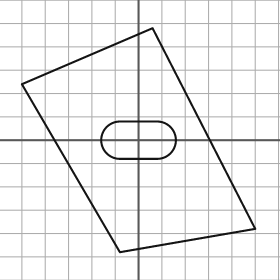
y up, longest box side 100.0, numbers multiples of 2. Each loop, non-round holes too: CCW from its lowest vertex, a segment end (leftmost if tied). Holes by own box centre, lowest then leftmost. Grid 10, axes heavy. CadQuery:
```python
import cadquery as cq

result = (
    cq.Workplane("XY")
    .moveTo(-8.0, -48.0)
    .lineTo(50.0, -38.0)
    .lineTo(6.0, 48.0)
    .lineTo(-50.0, 24.0)
    .close()
    .moveTo(-8.0, -8.0)
    .lineTo(8.0, -8.0)
    .threePointArc((16.0, 0.0), (8.0, 8.0))
    .lineTo(-8.0, 8.0)
    .threePointArc((-16.0, 0.0), (-8.0, -8.0))
    .close()
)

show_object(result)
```